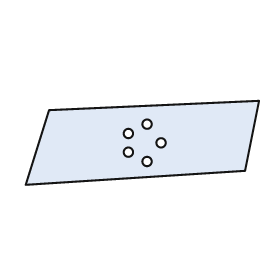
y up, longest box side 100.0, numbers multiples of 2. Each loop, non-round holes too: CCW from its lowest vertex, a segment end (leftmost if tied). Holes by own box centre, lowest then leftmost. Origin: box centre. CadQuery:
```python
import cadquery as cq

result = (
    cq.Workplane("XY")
    .moveTo(-50.0, -18.0)
    .lineTo(44.0, -12.0)
    .lineTo(50.0, 18.0)
    .lineTo(-40.0, 14.0)
    .close()
    .moveTo(2.0, -8.0)
    .circle(2.0)
    .moveTo(-6.0, -4.0)
    .circle(2.0)
    .moveTo(8.0, 0.0)
    .circle(2.0)
    .moveTo(-6.0, 4.0)
    .circle(2.0)
    .moveTo(2.0, 8.0)
    .circle(2.0)
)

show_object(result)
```